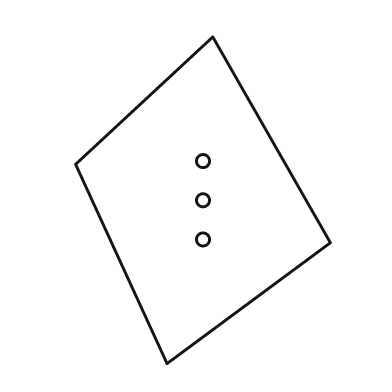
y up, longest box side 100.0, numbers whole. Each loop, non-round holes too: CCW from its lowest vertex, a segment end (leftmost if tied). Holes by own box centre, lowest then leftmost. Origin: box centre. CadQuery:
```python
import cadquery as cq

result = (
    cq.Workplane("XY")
    .moveTo(-11.0, -50.0)
    .lineTo(39.0, -13.0)
    .lineTo(3.0, 50.0)
    .lineTo(-39.0, 11.0)
    .close()
    .moveTo(0.0, -12.0)
    .circle(2.0)
    .moveTo(0.0, 0.0)
    .circle(2.0)
    .moveTo(0.0, 12.0)
    .circle(2.0)
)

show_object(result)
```